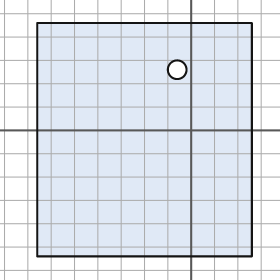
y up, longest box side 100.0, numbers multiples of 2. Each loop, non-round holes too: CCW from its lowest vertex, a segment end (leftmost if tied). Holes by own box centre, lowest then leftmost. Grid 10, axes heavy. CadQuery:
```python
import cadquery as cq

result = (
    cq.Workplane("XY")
    .moveTo(-66.0, -54.0)
    .lineTo(26.0, -54.0)
    .lineTo(26.0, 46.0)
    .lineTo(-66.0, 46.0)
    .close()
    .moveTo(-6.0, 26.0)
    .circle(4.0)
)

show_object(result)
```